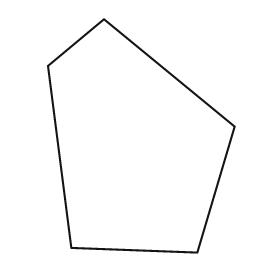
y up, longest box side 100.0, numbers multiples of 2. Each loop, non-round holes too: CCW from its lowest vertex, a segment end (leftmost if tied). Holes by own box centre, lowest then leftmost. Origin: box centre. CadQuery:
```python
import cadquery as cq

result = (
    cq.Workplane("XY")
    .moveTo(24.0, -50.0)
    .lineTo(40.0, 4.0)
    .lineTo(-16.0, 50.0)
    .lineTo(-40.0, 30.0)
    .lineTo(-30.0, -48.0)
    .close()
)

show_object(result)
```